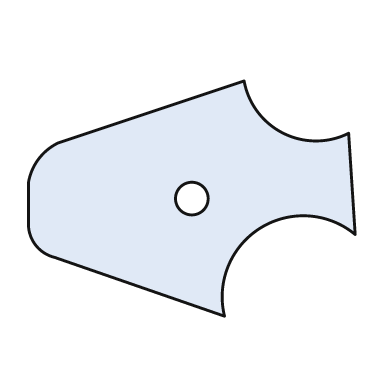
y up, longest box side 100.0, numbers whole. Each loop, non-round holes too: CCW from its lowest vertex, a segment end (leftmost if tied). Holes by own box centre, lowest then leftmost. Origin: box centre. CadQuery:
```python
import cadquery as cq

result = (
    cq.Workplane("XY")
    .moveTo(10.0, -36.0)
    .threePointArc((21.0, -9.0), (50.0, -11.0))
    .lineTo(48.0, 20.0)
    .threePointArc((28.0, 20.0), (16.0, 36.0))
    .lineTo(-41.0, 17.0)
    .threePointArc((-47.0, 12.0), (-50.0, 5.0))
    .lineTo(-50.0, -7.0)
    .threePointArc((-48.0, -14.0), (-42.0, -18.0))
    .close()
    .moveTo(0.0, 0.0)
    .circle(5.0)
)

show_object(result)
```